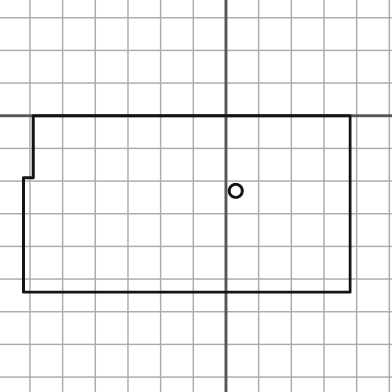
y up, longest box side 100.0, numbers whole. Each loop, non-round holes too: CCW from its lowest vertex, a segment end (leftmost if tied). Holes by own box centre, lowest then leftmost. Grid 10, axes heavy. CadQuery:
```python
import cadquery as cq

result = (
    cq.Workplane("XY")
    .moveTo(-62.0, -54.0)
    .lineTo(38.0, -54.0)
    .lineTo(38.0, 0.0)
    .lineTo(-59.0, 0.0)
    .lineTo(-59.0, -19.0)
    .lineTo(-62.0, -19.0)
    .close()
    .moveTo(3.0, -23.0)
    .circle(2.0)
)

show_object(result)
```